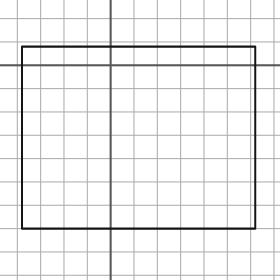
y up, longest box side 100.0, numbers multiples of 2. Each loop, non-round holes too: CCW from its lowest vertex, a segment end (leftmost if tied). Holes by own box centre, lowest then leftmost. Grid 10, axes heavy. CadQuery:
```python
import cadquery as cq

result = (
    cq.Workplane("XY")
    .moveTo(-38.0, -70.0)
    .lineTo(62.0, -70.0)
    .lineTo(62.0, 8.0)
    .lineTo(-38.0, 8.0)
    .close()
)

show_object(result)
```